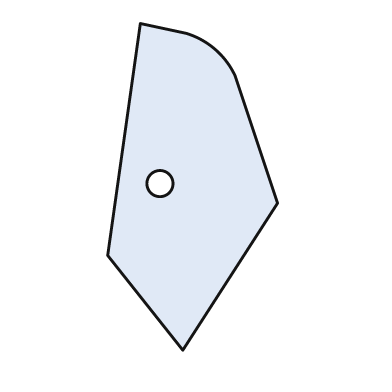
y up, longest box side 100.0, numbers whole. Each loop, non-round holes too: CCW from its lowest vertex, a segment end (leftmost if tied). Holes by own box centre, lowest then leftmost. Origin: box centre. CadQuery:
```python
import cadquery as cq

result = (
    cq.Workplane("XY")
    .moveTo(-3.0, -50.0)
    .lineTo(26.0, -5.0)
    .lineTo(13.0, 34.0)
    .threePointArc((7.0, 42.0), (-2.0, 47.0))
    .lineTo(-16.0, 50.0)
    .lineTo(-26.0, -21.0)
    .close()
    .moveTo(-10.0, 1.0)
    .circle(4.0)
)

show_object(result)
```